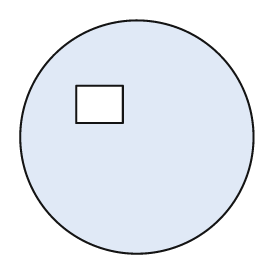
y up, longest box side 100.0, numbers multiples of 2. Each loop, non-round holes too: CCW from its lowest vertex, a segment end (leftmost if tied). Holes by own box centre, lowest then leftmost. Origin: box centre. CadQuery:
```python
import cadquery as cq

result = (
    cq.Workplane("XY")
    .moveTo(0.0, 0.0)
    .circle(50.0)
    .moveTo(-26.0, 6.0)
    .lineTo(-6.0, 6.0)
    .lineTo(-6.0, 22.0)
    .lineTo(-26.0, 22.0)
    .close()
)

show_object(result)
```